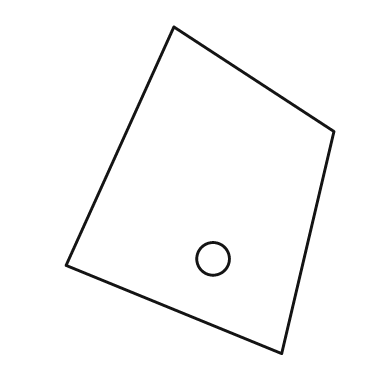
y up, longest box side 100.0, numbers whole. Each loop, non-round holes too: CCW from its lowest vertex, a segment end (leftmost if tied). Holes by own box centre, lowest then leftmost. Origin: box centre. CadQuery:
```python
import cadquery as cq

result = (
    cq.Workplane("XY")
    .moveTo(25.0, -50.0)
    .lineTo(41.0, 18.0)
    .lineTo(-8.0, 50.0)
    .lineTo(-41.0, -23.0)
    .close()
    .moveTo(4.0, -21.0)
    .circle(5.0)
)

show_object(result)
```